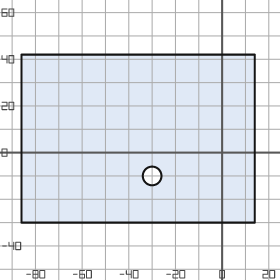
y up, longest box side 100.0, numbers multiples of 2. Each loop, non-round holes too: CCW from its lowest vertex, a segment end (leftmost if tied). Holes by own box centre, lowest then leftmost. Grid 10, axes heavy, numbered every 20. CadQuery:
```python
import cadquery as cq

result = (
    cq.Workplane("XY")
    .moveTo(-86.0, -30.0)
    .lineTo(14.0, -30.0)
    .lineTo(14.0, 42.0)
    .lineTo(-86.0, 42.0)
    .close()
    .moveTo(-30.0, -10.0)
    .circle(4.0)
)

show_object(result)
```